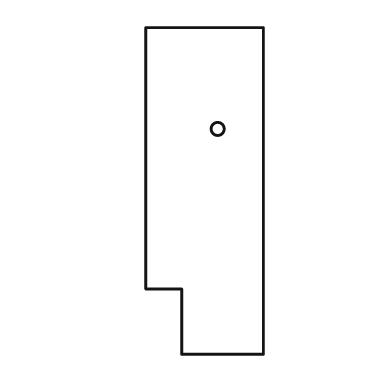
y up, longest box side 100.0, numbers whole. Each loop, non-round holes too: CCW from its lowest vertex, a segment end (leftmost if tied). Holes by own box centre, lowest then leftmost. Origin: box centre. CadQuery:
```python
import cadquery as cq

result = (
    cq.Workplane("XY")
    .moveTo(-7.0, -50.0)
    .lineTo(18.0, -50.0)
    .lineTo(18.0, 50.0)
    .lineTo(-18.0, 50.0)
    .lineTo(-18.0, -30.0)
    .lineTo(-7.0, -30.0)
    .close()
    .moveTo(4.0, 19.0)
    .circle(2.0)
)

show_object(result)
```